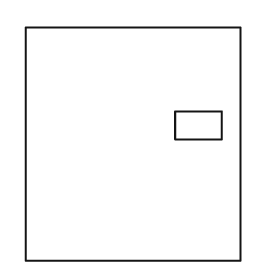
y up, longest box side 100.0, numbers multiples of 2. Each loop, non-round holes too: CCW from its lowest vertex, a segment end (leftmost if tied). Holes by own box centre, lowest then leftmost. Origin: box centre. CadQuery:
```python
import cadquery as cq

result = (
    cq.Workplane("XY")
    .moveTo(-46.0, -50.0)
    .lineTo(46.0, -50.0)
    .lineTo(46.0, 50.0)
    .lineTo(-46.0, 50.0)
    .close()
    .moveTo(18.0, 2.0)
    .lineTo(38.0, 2.0)
    .lineTo(38.0, 14.0)
    .lineTo(18.0, 14.0)
    .close()
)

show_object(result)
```